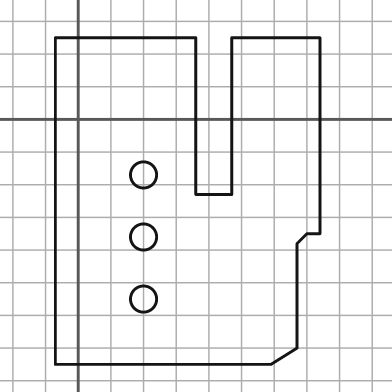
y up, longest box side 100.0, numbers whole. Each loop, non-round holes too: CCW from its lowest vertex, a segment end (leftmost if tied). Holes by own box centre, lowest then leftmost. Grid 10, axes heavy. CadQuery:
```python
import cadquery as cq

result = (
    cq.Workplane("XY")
    .moveTo(-7.0, -75.0)
    .lineTo(59.0, -75.0)
    .lineTo(67.0, -70.0)
    .lineTo(67.0, -38.0)
    .lineTo(70.0, -35.0)
    .lineTo(74.0, -35.0)
    .lineTo(74.0, 25.0)
    .lineTo(47.0, 25.0)
    .lineTo(47.0, -23.0)
    .lineTo(36.0, -23.0)
    .lineTo(36.0, 25.0)
    .lineTo(-7.0, 25.0)
    .close()
    .moveTo(20.0, -55.0)
    .circle(4.0)
    .moveTo(20.0, -36.0)
    .circle(4.0)
    .moveTo(20.0, -17.0)
    .circle(4.0)
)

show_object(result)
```